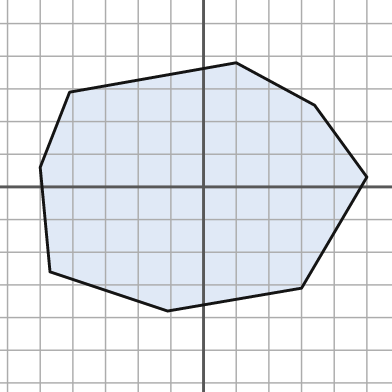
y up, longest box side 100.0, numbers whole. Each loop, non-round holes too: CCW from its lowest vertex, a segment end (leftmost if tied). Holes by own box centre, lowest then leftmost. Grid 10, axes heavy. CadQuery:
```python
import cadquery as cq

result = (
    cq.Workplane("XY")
    .moveTo(-11.0, -38.0)
    .lineTo(30.0, -31.0)
    .lineTo(50.0, 3.0)
    .lineTo(34.0, 25.0)
    .lineTo(10.0, 38.0)
    .lineTo(-41.0, 29.0)
    .lineTo(-50.0, 6.0)
    .lineTo(-47.0, -26.0)
    .close()
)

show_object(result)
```